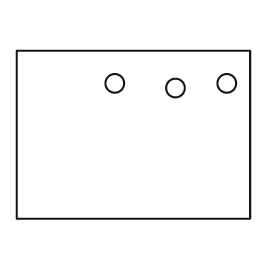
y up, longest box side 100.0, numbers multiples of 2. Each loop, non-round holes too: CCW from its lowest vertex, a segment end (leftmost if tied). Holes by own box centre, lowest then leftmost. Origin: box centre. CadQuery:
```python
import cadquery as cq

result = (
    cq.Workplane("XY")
    .moveTo(-50.0, -36.0)
    .lineTo(50.0, -36.0)
    .lineTo(50.0, 36.0)
    .lineTo(-50.0, 36.0)
    .close()
    .moveTo(18.0, 20.0)
    .circle(4.0)
    .moveTo(-8.0, 22.0)
    .circle(4.0)
    .moveTo(40.0, 22.0)
    .circle(4.0)
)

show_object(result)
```